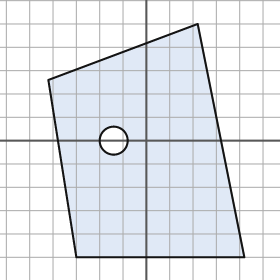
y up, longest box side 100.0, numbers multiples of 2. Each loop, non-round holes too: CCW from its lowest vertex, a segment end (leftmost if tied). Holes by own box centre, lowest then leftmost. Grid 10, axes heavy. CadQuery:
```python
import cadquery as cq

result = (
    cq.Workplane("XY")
    .moveTo(-30.0, -50.0)
    .lineTo(42.0, -50.0)
    .lineTo(22.0, 50.0)
    .lineTo(-42.0, 26.0)
    .close()
    .moveTo(-14.0, 0.0)
    .circle(6.0)
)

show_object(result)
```